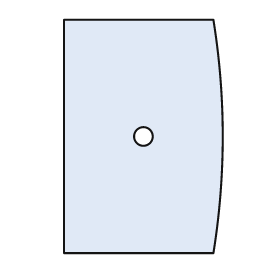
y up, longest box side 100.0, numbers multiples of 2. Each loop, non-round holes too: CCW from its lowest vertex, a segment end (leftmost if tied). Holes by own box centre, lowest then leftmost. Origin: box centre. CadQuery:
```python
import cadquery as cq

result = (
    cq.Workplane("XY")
    .moveTo(-34.0, -50.0)
    .lineTo(30.0, -50.0)
    .threePointArc((34.0, 0.0), (30.0, 50.0))
    .lineTo(-34.0, 50.0)
    .close()
    .moveTo(0.0, 0.0)
    .circle(4.0)
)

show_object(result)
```